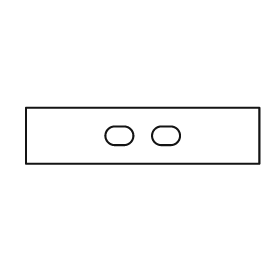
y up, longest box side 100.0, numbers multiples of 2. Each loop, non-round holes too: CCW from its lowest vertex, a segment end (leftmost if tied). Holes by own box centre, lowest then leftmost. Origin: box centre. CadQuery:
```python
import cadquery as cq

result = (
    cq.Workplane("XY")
    .moveTo(-50.0, -12.0)
    .lineTo(50.0, -12.0)
    .lineTo(50.0, 12.0)
    .lineTo(-50.0, 12.0)
    .close()
    .moveTo(-12.0, -4.0)
    .lineTo(-8.0, -4.0)
    .threePointArc((-4.0, 0.0), (-8.0, 4.0))
    .lineTo(-12.0, 4.0)
    .threePointArc((-16.0, 0.0), (-12.0, -4.0))
    .close()
    .moveTo(8.0, -4.0)
    .lineTo(12.0, -4.0)
    .threePointArc((16.0, 0.0), (12.0, 4.0))
    .lineTo(8.0, 4.0)
    .threePointArc((4.0, 0.0), (8.0, -4.0))
    .close()
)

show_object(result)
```